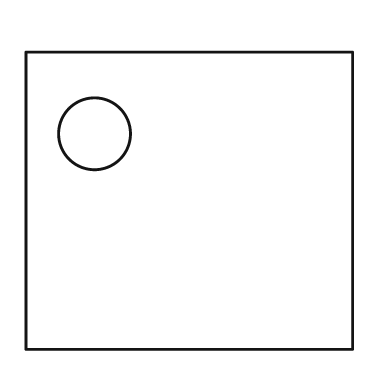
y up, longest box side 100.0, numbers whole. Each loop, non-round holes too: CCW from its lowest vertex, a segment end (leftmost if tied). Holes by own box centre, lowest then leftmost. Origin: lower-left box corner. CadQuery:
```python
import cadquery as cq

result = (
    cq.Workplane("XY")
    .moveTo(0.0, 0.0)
    .lineTo(100.0, 0.0)
    .lineTo(100.0, 91.0)
    .lineTo(0.0, 91.0)
    .close()
    .moveTo(21.0, 66.0)
    .circle(11.0)
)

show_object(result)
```